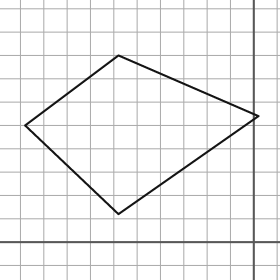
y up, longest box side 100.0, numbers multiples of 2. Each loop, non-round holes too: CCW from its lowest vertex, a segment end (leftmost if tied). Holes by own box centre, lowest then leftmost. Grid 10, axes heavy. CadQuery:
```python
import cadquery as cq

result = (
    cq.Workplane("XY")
    .moveTo(-58.0, 12.0)
    .lineTo(2.0, 54.0)
    .lineTo(-58.0, 80.0)
    .lineTo(-98.0, 50.0)
    .close()
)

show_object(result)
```